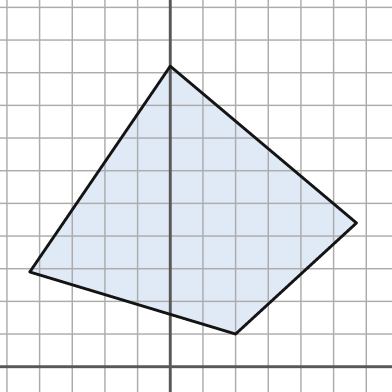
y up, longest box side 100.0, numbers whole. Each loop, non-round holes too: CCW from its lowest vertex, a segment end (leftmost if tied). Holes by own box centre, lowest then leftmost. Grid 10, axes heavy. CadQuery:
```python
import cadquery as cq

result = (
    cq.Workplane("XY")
    .moveTo(20.0, 10.0)
    .lineTo(57.0, 44.0)
    .lineTo(0.0, 92.0)
    .lineTo(-43.0, 29.0)
    .close()
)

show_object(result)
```